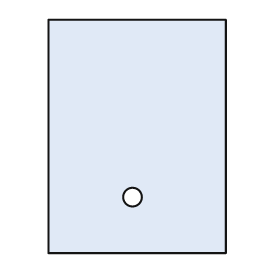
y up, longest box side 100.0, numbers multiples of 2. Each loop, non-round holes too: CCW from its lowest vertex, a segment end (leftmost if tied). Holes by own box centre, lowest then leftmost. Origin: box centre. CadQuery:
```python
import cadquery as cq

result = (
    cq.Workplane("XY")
    .moveTo(-38.0, -50.0)
    .lineTo(38.0, -50.0)
    .lineTo(38.0, 50.0)
    .lineTo(-38.0, 50.0)
    .close()
    .moveTo(-2.0, -26.0)
    .circle(4.0)
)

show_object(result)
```